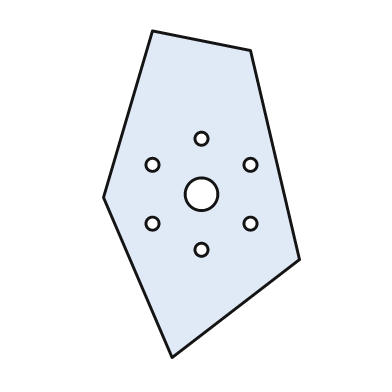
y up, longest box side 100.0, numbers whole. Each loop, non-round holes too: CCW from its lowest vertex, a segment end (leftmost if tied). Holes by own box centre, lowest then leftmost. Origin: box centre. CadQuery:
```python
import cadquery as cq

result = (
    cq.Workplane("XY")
    .moveTo(-9.0, -50.0)
    .lineTo(30.0, -20.0)
    .lineTo(15.0, 44.0)
    .lineTo(-15.0, 50.0)
    .lineTo(-30.0, -1.0)
    .close()
    .moveTo(0.0, -17.0)
    .circle(2.0)
    .moveTo(-15.0, -9.0)
    .circle(2.0)
    .moveTo(15.0, -9.0)
    .circle(2.0)
    .moveTo(0.0, 0.0)
    .circle(5.0)
    .moveTo(-15.0, 9.0)
    .circle(2.0)
    .moveTo(15.0, 9.0)
    .circle(2.0)
    .moveTo(0.0, 17.0)
    .circle(2.0)
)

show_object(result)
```